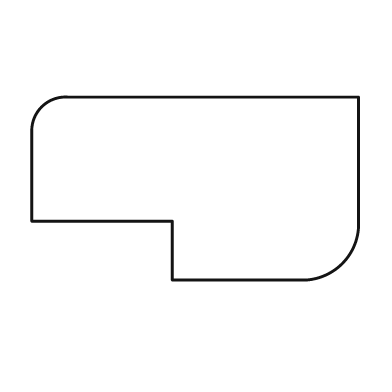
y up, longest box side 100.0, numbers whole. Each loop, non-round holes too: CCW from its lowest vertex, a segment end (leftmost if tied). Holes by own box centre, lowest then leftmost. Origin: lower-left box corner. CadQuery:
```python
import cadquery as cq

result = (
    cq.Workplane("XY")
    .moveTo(43.0, 0.0)
    .lineTo(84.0, 0.0)
    .threePointArc((95.0, 5.0), (100.0, 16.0))
    .lineTo(100.0, 56.0)
    .lineTo(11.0, 56.0)
    .threePointArc((3.0, 53.0), (0.0, 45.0))
    .lineTo(0.0, 18.0)
    .lineTo(43.0, 18.0)
    .close()
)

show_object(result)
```